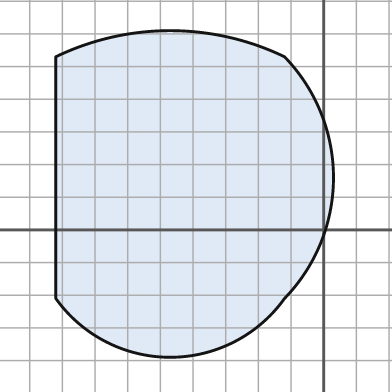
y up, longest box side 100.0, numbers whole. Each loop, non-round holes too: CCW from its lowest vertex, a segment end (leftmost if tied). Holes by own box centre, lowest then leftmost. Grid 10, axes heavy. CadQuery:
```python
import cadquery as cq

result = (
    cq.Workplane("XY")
    .moveTo(-82.0, -21.0)
    .threePointArc((-47.0, -39.0), (-12.0, -21.0))
    .threePointArc((3.0, 16.0), (-12.0, 53.0))
    .threePointArc((-47.0, 61.0), (-82.0, 53.0))
    .close()
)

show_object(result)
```